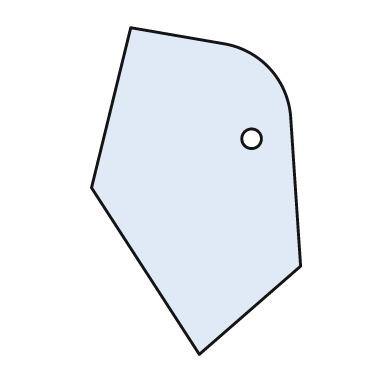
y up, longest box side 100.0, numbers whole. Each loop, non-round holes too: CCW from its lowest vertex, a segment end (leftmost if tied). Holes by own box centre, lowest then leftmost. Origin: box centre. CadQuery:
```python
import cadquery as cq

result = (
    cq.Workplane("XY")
    .moveTo(1.0, -50.0)
    .lineTo(32.0, -23.0)
    .lineTo(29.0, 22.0)
    .threePointArc((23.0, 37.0), (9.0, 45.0))
    .lineTo(-20.0, 50.0)
    .lineTo(-32.0, 1.0)
    .close()
    .moveTo(17.0, 16.0)
    .circle(3.0)
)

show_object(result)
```